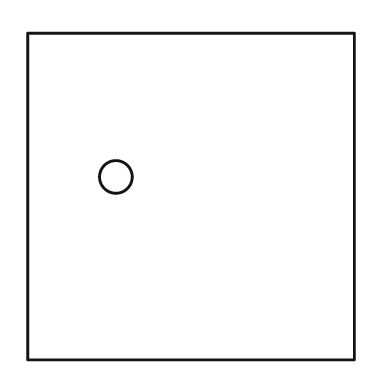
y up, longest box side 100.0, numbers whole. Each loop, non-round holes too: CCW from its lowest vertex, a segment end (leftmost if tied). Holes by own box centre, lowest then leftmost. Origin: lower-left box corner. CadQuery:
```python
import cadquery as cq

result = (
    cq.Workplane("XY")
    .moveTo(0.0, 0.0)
    .lineTo(100.0, 0.0)
    .lineTo(100.0, 100.0)
    .lineTo(0.0, 100.0)
    .close()
    .moveTo(27.0, 56.0)
    .circle(5.0)
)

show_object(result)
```